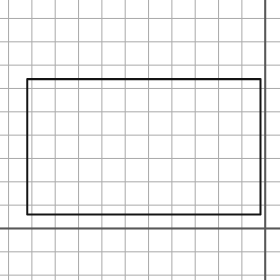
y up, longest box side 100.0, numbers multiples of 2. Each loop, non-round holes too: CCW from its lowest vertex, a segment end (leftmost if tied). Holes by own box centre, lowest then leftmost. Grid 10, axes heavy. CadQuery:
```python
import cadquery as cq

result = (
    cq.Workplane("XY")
    .moveTo(-102.0, 6.0)
    .lineTo(-2.0, 6.0)
    .lineTo(-2.0, 64.0)
    .lineTo(-102.0, 64.0)
    .close()
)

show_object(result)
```